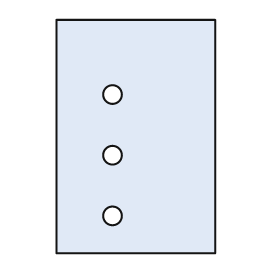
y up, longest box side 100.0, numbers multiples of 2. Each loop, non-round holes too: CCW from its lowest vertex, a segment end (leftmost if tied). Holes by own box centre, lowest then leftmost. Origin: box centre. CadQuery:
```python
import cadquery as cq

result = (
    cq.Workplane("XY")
    .moveTo(-34.0, -50.0)
    .lineTo(34.0, -50.0)
    .lineTo(34.0, 50.0)
    .lineTo(-34.0, 50.0)
    .close()
    .moveTo(-10.0, -34.0)
    .circle(4.0)
    .moveTo(-10.0, -8.0)
    .circle(4.0)
    .moveTo(-10.0, 18.0)
    .circle(4.0)
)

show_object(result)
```